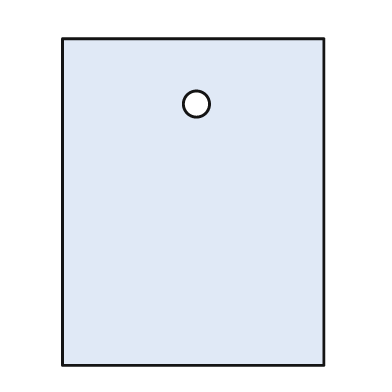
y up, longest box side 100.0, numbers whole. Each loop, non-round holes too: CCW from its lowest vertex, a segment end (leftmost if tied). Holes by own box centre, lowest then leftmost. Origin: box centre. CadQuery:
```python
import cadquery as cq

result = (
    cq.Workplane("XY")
    .moveTo(-40.0, -50.0)
    .lineTo(40.0, -50.0)
    .lineTo(40.0, 50.0)
    .lineTo(-40.0, 50.0)
    .close()
    .moveTo(1.0, 30.0)
    .circle(4.0)
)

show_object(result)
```